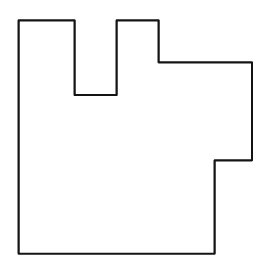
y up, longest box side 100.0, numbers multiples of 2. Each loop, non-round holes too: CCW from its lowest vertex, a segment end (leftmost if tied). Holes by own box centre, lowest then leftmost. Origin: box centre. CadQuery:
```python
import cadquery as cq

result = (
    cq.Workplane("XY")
    .moveTo(-50.0, -50.0)
    .lineTo(34.0, -50.0)
    .lineTo(34.0, -10.0)
    .lineTo(50.0, -10.0)
    .lineTo(50.0, 32.0)
    .lineTo(10.0, 32.0)
    .lineTo(10.0, 50.0)
    .lineTo(-8.0, 50.0)
    .lineTo(-8.0, 18.0)
    .lineTo(-26.0, 18.0)
    .lineTo(-26.0, 50.0)
    .lineTo(-50.0, 50.0)
    .close()
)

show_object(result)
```